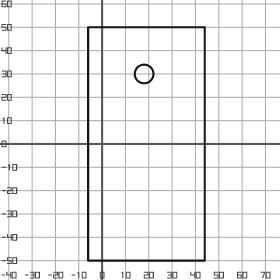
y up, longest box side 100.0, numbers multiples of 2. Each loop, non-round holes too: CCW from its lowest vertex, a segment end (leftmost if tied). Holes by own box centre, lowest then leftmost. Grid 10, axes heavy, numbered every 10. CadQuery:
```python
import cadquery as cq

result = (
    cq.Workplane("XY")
    .moveTo(-6.0, -50.0)
    .lineTo(44.0, -50.0)
    .lineTo(44.0, 50.0)
    .lineTo(-6.0, 50.0)
    .close()
    .moveTo(18.0, 30.0)
    .circle(4.0)
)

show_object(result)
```